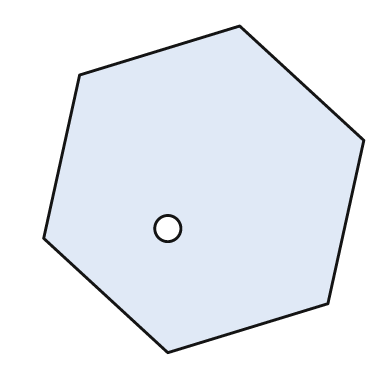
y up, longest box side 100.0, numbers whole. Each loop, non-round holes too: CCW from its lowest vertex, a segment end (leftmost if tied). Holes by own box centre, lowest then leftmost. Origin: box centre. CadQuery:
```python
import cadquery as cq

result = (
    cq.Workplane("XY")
    .moveTo(-11.0, -50.0)
    .lineTo(38.0, -35.0)
    .lineTo(49.0, 15.0)
    .lineTo(11.0, 50.0)
    .lineTo(-38.0, 35.0)
    .lineTo(-49.0, -15.0)
    .close()
    .moveTo(-11.0, -12.0)
    .circle(4.0)
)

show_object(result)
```